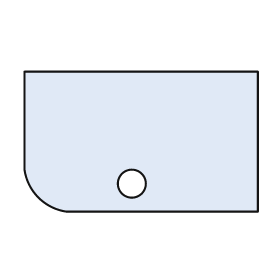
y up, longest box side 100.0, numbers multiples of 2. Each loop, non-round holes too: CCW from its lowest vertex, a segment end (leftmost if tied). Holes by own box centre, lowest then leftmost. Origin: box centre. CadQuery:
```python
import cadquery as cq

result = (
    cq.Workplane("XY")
    .moveTo(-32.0, -30.0)
    .lineTo(50.0, -30.0)
    .lineTo(50.0, 30.0)
    .lineTo(-50.0, 30.0)
    .lineTo(-50.0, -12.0)
    .threePointArc((-44.0, -24.0), (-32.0, -30.0))
    .close()
    .moveTo(-4.0, -18.0)
    .circle(6.0)
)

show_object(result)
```